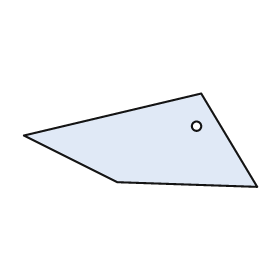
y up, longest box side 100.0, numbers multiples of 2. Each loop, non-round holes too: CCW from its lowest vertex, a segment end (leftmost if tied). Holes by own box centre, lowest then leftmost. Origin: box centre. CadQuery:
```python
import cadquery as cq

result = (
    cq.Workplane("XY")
    .moveTo(50.0, -20.0)
    .lineTo(26.0, 20.0)
    .lineTo(-50.0, 2.0)
    .lineTo(-10.0, -18.0)
    .close()
    .moveTo(24.0, 6.0)
    .circle(2.0)
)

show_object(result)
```